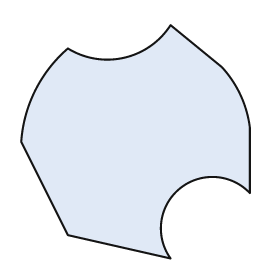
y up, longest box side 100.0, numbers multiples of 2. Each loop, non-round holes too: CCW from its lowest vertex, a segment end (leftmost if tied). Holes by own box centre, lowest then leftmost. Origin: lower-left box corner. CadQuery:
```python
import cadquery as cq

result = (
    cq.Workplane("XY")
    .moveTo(64.0, 0.0)
    .threePointArc((68.0, 30.0), (98.0, 28.0))
    .lineTo(98.0, 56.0)
    .threePointArc((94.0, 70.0), (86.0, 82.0))
    .lineTo(64.0, 100.0)
    .threePointArc((44.0, 86.0), (20.0, 90.0))
    .threePointArc((6.0, 72.0), (0.0, 50.0))
    .lineTo(20.0, 10.0)
    .close()
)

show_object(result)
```